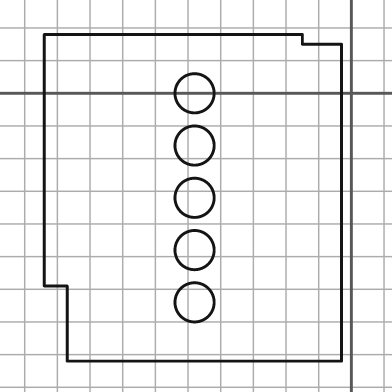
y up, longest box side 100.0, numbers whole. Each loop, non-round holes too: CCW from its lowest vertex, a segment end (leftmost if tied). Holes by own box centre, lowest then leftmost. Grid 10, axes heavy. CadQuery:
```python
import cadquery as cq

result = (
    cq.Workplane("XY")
    .moveTo(-87.0, -82.0)
    .lineTo(-3.0, -82.0)
    .lineTo(-3.0, 15.0)
    .lineTo(-15.0, 15.0)
    .lineTo(-15.0, 18.0)
    .lineTo(-94.0, 18.0)
    .lineTo(-94.0, -59.0)
    .lineTo(-87.0, -59.0)
    .close()
    .moveTo(-48.0, -64.0)
    .circle(6.0)
    .moveTo(-48.0, -48.0)
    .circle(6.0)
    .moveTo(-48.0, -32.0)
    .circle(6.0)
    .moveTo(-48.0, -16.0)
    .circle(6.0)
    .moveTo(-48.0, 0.0)
    .circle(6.0)
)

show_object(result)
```